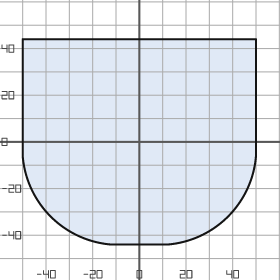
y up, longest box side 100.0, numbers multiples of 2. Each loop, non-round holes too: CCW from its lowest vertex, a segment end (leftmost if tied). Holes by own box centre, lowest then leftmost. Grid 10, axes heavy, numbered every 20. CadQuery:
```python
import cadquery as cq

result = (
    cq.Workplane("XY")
    .moveTo(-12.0, -44.0)
    .lineTo(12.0, -44.0)
    .threePointArc((38.0, -32.0), (50.0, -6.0))
    .lineTo(50.0, 44.0)
    .lineTo(-50.0, 44.0)
    .lineTo(-50.0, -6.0)
    .threePointArc((-38.0, -32.0), (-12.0, -44.0))
    .close()
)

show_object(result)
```